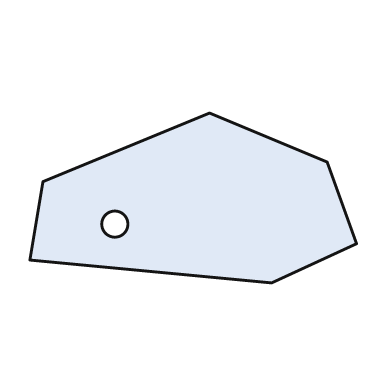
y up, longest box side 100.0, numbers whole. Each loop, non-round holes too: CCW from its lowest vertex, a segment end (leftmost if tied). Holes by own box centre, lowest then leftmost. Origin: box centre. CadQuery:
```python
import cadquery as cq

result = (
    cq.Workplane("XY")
    .moveTo(24.0, -26.0)
    .lineTo(50.0, -14.0)
    .lineTo(41.0, 11.0)
    .lineTo(5.0, 26.0)
    .lineTo(-46.0, 5.0)
    .lineTo(-50.0, -19.0)
    .close()
    .moveTo(-24.0, -8.0)
    .circle(4.0)
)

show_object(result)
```